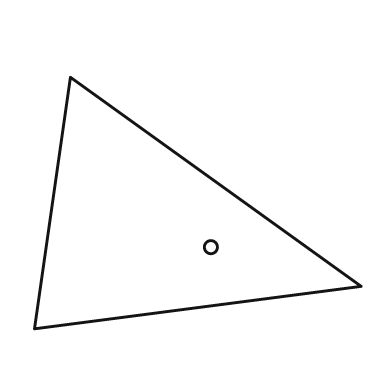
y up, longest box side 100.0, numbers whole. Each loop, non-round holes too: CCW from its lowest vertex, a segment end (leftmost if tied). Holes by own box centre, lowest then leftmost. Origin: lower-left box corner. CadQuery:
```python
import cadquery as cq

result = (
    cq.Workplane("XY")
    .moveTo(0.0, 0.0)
    .lineTo(100.0, 13.0)
    .lineTo(11.0, 77.0)
    .close()
    .moveTo(54.0, 25.0)
    .circle(2.0)
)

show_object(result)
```